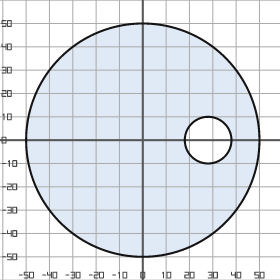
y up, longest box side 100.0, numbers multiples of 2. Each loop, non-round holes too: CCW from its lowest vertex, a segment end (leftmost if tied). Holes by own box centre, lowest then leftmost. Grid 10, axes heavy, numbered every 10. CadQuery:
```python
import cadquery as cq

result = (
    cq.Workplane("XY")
    .moveTo(0.0, 0.0)
    .circle(50.0)
    .moveTo(28.0, 0.0)
    .circle(10.0)
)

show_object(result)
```